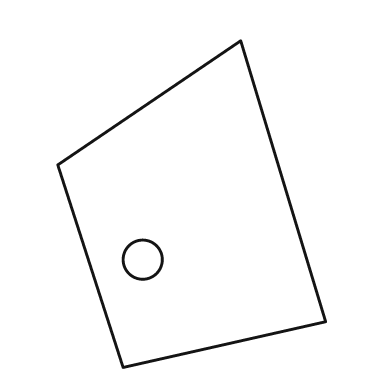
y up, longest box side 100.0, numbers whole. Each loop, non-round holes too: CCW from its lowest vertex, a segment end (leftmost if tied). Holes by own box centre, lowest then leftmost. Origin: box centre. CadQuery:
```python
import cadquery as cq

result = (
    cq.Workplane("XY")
    .moveTo(-21.0, -50.0)
    .lineTo(41.0, -36.0)
    .lineTo(15.0, 50.0)
    .lineTo(-41.0, 12.0)
    .close()
    .moveTo(-15.0, -17.0)
    .circle(6.0)
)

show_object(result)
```